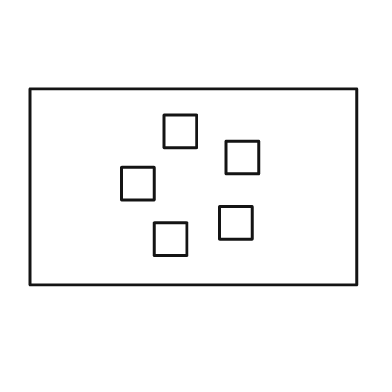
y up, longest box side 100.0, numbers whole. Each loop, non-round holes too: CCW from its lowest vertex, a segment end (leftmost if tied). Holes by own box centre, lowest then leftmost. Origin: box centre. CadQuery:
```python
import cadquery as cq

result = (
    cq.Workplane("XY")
    .moveTo(-50.0, -30.0)
    .lineTo(50.0, -30.0)
    .lineTo(50.0, 30.0)
    .lineTo(-50.0, 30.0)
    .close()
    .moveTo(-12.0, -21.0)
    .lineTo(-2.0, -21.0)
    .lineTo(-2.0, -11.0)
    .lineTo(-12.0, -11.0)
    .close()
    .moveTo(8.0, -16.0)
    .lineTo(18.0, -16.0)
    .lineTo(18.0, -6.0)
    .lineTo(8.0, -6.0)
    .close()
    .moveTo(-22.0, -4.0)
    .lineTo(-12.0, -4.0)
    .lineTo(-12.0, 6.0)
    .lineTo(-22.0, 6.0)
    .close()
    .moveTo(10.0, 4.0)
    .lineTo(20.0, 4.0)
    .lineTo(20.0, 14.0)
    .lineTo(10.0, 14.0)
    .close()
    .moveTo(-9.0, 12.0)
    .lineTo(1.0, 12.0)
    .lineTo(1.0, 22.0)
    .lineTo(-9.0, 22.0)
    .close()
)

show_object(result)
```